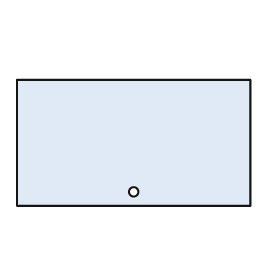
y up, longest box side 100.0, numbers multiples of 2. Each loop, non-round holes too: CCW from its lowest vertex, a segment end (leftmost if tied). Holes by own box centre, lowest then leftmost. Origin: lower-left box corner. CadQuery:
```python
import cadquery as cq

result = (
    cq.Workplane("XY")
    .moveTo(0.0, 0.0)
    .lineTo(100.0, 0.0)
    .lineTo(100.0, 54.0)
    .lineTo(0.0, 54.0)
    .close()
    .moveTo(50.0, 6.0)
    .circle(2.0)
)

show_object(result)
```